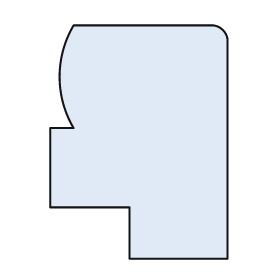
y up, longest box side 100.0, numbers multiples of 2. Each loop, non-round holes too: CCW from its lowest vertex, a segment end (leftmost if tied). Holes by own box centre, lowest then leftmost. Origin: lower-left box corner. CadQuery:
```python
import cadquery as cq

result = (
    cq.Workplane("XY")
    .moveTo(34.0, 0.0)
    .lineTo(76.0, 0.0)
    .lineTo(76.0, 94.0)
    .threePointArc((74.0, 98.0), (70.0, 100.0))
    .lineTo(10.0, 100.0)
    .threePointArc((4.0, 78.0), (10.0, 56.0))
    .lineTo(0.0, 56.0)
    .lineTo(0.0, 22.0)
    .lineTo(34.0, 22.0)
    .close()
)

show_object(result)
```